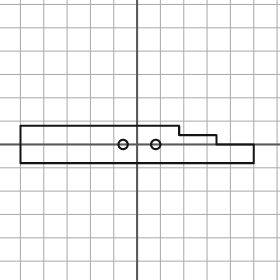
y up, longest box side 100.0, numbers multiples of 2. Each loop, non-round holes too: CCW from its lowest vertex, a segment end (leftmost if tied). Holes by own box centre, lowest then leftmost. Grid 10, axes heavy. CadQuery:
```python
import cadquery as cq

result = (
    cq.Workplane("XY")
    .moveTo(-50.0, -8.0)
    .lineTo(50.0, -8.0)
    .lineTo(50.0, 0.0)
    .lineTo(34.0, 0.0)
    .lineTo(34.0, 4.0)
    .lineTo(18.0, 4.0)
    .lineTo(18.0, 8.0)
    .lineTo(-50.0, 8.0)
    .close()
    .moveTo(-6.0, 0.0)
    .circle(2.0)
    .moveTo(8.0, 0.0)
    .circle(2.0)
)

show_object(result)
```